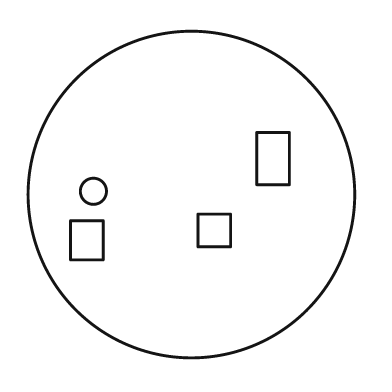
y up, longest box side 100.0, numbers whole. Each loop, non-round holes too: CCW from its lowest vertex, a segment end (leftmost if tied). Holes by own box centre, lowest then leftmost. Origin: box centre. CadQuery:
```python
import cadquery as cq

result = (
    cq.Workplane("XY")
    .moveTo(0.0, 0.0)
    .circle(50.0)
    .moveTo(-37.0, -20.0)
    .lineTo(-27.0, -20.0)
    .lineTo(-27.0, -8.0)
    .lineTo(-37.0, -8.0)
    .close()
    .moveTo(2.0, -16.0)
    .lineTo(12.0, -16.0)
    .lineTo(12.0, -6.0)
    .lineTo(2.0, -6.0)
    .close()
    .moveTo(-30.0, 1.0)
    .circle(4.0)
    .moveTo(20.0, 3.0)
    .lineTo(30.0, 3.0)
    .lineTo(30.0, 19.0)
    .lineTo(20.0, 19.0)
    .close()
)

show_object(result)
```